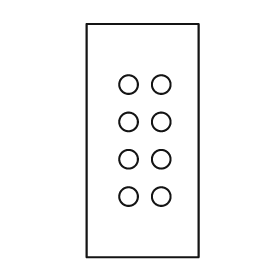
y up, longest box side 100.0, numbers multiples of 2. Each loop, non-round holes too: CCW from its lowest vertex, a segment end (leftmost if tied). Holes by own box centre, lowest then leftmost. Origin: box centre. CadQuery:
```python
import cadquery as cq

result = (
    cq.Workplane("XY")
    .moveTo(-24.0, -50.0)
    .lineTo(24.0, -50.0)
    .lineTo(24.0, 50.0)
    .lineTo(-24.0, 50.0)
    .close()
    .moveTo(-6.0, -24.0)
    .circle(4.0)
    .moveTo(8.0, -24.0)
    .circle(4.0)
    .moveTo(-6.0, -8.0)
    .circle(4.0)
    .moveTo(8.0, -8.0)
    .circle(4.0)
    .moveTo(-6.0, 8.0)
    .circle(4.0)
    .moveTo(8.0, 8.0)
    .circle(4.0)
    .moveTo(-6.0, 24.0)
    .circle(4.0)
    .moveTo(8.0, 24.0)
    .circle(4.0)
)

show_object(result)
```